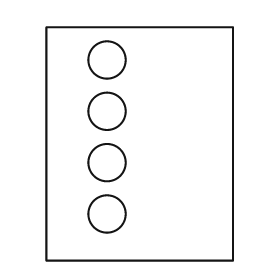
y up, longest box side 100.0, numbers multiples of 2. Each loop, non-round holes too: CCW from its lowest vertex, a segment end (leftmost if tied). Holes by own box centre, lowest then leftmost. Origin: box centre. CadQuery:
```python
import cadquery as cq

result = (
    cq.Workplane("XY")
    .moveTo(-40.0, -50.0)
    .lineTo(40.0, -50.0)
    .lineTo(40.0, 50.0)
    .lineTo(-40.0, 50.0)
    .close()
    .moveTo(-14.0, -30.0)
    .circle(8.0)
    .moveTo(-14.0, -8.0)
    .circle(8.0)
    .moveTo(-14.0, 14.0)
    .circle(8.0)
    .moveTo(-14.0, 36.0)
    .circle(8.0)
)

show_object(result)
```